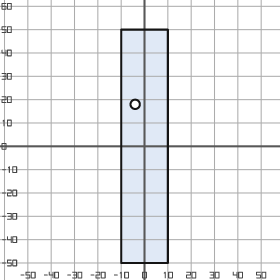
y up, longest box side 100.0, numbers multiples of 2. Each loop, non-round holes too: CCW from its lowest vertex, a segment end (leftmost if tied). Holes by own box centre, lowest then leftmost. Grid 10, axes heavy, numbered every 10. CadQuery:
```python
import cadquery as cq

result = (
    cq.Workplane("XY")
    .moveTo(-10.0, -50.0)
    .lineTo(10.0, -50.0)
    .lineTo(10.0, 50.0)
    .lineTo(-10.0, 50.0)
    .close()
    .moveTo(-4.0, 18.0)
    .circle(2.0)
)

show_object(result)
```